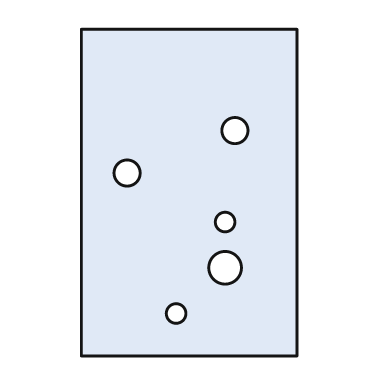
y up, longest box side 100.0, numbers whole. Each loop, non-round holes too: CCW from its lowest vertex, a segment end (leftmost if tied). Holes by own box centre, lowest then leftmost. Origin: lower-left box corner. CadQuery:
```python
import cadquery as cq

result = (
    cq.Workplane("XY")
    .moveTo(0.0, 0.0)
    .lineTo(66.0, 0.0)
    .lineTo(66.0, 100.0)
    .lineTo(0.0, 100.0)
    .close()
    .moveTo(29.0, 13.0)
    .circle(3.0)
    .moveTo(44.0, 27.0)
    .circle(5.0)
    .moveTo(44.0, 41.0)
    .circle(3.0)
    .moveTo(14.0, 56.0)
    .circle(4.0)
    .moveTo(47.0, 69.0)
    .circle(4.0)
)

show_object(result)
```